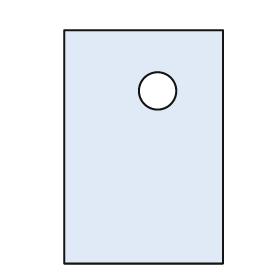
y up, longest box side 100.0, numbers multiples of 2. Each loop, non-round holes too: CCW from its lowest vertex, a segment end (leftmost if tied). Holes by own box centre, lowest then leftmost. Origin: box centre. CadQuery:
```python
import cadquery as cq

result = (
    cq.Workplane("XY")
    .moveTo(-34.0, -50.0)
    .lineTo(34.0, -50.0)
    .lineTo(34.0, 50.0)
    .lineTo(-34.0, 50.0)
    .close()
    .moveTo(6.0, 24.0)
    .circle(8.0)
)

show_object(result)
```